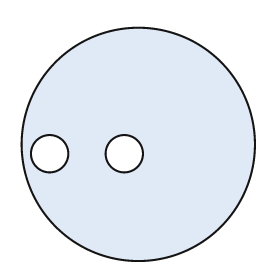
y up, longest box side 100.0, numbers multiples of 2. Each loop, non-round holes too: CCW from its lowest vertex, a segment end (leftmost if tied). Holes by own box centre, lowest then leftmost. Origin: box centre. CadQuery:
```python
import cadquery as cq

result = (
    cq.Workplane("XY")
    .moveTo(0.0, 0.0)
    .circle(50.0)
    .moveTo(-38.0, -4.0)
    .circle(8.0)
    .moveTo(-6.0, -4.0)
    .circle(8.0)
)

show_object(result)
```